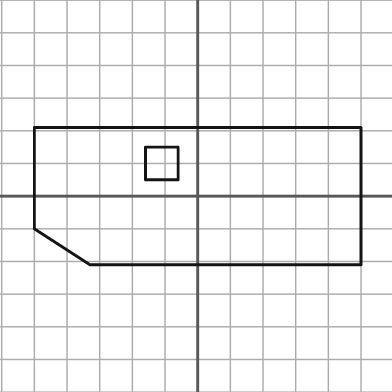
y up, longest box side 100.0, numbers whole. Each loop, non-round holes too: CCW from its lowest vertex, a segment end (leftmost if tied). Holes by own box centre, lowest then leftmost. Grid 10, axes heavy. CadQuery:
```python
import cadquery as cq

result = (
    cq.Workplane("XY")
    .moveTo(-33.0, -21.0)
    .lineTo(50.0, -21.0)
    .lineTo(50.0, 21.0)
    .lineTo(-50.0, 21.0)
    .lineTo(-50.0, -10.0)
    .close()
    .moveTo(-16.0, 5.0)
    .lineTo(-6.0, 5.0)
    .lineTo(-6.0, 15.0)
    .lineTo(-16.0, 15.0)
    .close()
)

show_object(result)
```